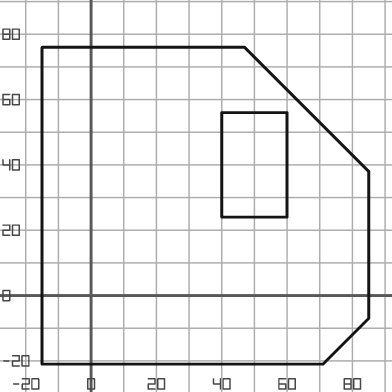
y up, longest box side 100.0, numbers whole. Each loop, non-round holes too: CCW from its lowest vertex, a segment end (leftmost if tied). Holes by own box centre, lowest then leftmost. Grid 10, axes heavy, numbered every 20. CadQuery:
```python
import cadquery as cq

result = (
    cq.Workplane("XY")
    .moveTo(-15.0, -21.0)
    .lineTo(71.0, -21.0)
    .lineTo(85.0, -7.0)
    .lineTo(85.0, 38.0)
    .lineTo(47.0, 76.0)
    .lineTo(-15.0, 76.0)
    .close()
    .moveTo(40.0, 24.0)
    .lineTo(60.0, 24.0)
    .lineTo(60.0, 56.0)
    .lineTo(40.0, 56.0)
    .close()
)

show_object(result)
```